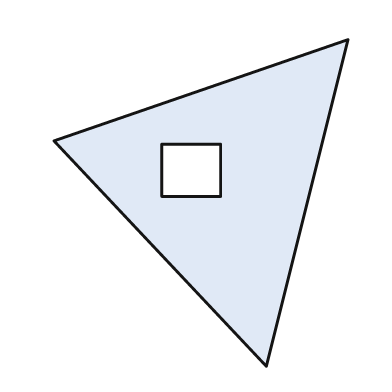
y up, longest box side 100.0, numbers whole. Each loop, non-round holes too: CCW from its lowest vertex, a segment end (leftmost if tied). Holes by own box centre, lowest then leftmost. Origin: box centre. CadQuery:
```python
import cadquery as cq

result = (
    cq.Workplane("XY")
    .moveTo(20.0, -50.0)
    .lineTo(45.0, 50.0)
    .lineTo(-45.0, 19.0)
    .close()
    .moveTo(-12.0, 2.0)
    .lineTo(6.0, 2.0)
    .lineTo(6.0, 18.0)
    .lineTo(-12.0, 18.0)
    .close()
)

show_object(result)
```